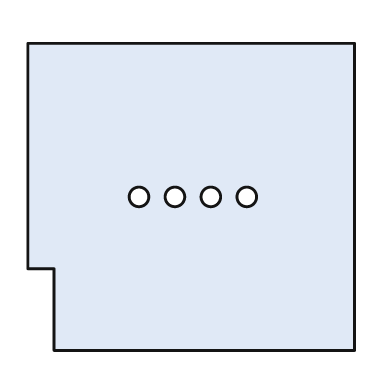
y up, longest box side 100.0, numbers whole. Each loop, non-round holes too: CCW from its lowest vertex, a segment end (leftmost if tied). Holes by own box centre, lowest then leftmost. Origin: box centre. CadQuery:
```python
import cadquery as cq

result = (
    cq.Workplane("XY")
    .moveTo(-42.0, -47.0)
    .lineTo(50.0, -47.0)
    .lineTo(50.0, 47.0)
    .lineTo(-50.0, 47.0)
    .lineTo(-50.0, -22.0)
    .lineTo(-42.0, -22.0)
    .close()
    .moveTo(-16.0, 0.0)
    .circle(3.0)
    .moveTo(-5.0, 0.0)
    .circle(3.0)
    .moveTo(6.0, 0.0)
    .circle(3.0)
    .moveTo(17.0, 0.0)
    .circle(3.0)
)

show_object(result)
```